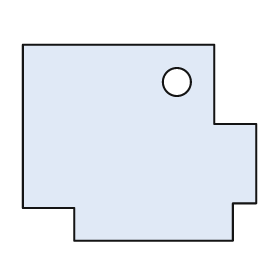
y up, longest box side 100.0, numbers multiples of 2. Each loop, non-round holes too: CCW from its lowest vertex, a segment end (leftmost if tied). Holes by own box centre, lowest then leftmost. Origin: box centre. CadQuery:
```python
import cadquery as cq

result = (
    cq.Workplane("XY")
    .moveTo(-28.0, -42.0)
    .lineTo(40.0, -42.0)
    .lineTo(40.0, -26.0)
    .lineTo(50.0, -26.0)
    .lineTo(50.0, 8.0)
    .lineTo(32.0, 8.0)
    .lineTo(32.0, 42.0)
    .lineTo(-50.0, 42.0)
    .lineTo(-50.0, -28.0)
    .lineTo(-28.0, -28.0)
    .close()
    .moveTo(16.0, 26.0)
    .circle(6.0)
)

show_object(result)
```